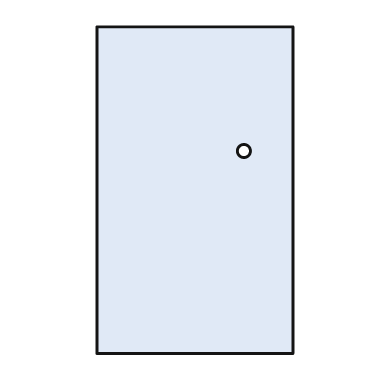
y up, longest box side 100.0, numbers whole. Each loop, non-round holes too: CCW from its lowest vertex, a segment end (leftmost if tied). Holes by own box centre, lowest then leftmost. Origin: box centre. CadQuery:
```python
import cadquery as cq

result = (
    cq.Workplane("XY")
    .moveTo(-30.0, -50.0)
    .lineTo(30.0, -50.0)
    .lineTo(30.0, 50.0)
    .lineTo(-30.0, 50.0)
    .close()
    .moveTo(15.0, 12.0)
    .circle(2.0)
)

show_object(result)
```